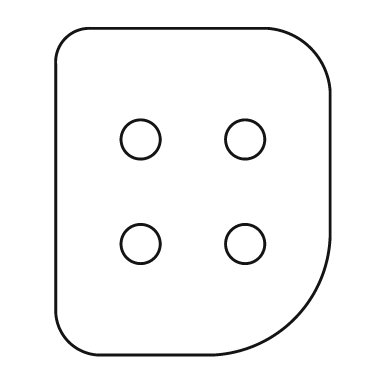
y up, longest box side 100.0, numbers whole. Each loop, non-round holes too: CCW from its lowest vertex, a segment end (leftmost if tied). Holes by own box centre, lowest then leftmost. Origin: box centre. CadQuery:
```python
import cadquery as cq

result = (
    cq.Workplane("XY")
    .moveTo(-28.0, -50.0)
    .lineTo(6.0, -50.0)
    .threePointArc((31.0, -39.0), (42.0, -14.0))
    .lineTo(42.0, 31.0)
    .threePointArc((36.0, 44.0), (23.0, 50.0))
    .lineTo(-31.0, 50.0)
    .threePointArc((-39.0, 47.0), (-42.0, 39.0))
    .lineTo(-42.0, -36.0)
    .threePointArc((-38.0, -46.0), (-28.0, -50.0))
    .close()
    .moveTo(-16.0, -16.0)
    .circle(6.0)
    .moveTo(16.0, -16.0)
    .circle(6.0)
    .moveTo(-16.0, 16.0)
    .circle(6.0)
    .moveTo(16.0, 16.0)
    .circle(6.0)
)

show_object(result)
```